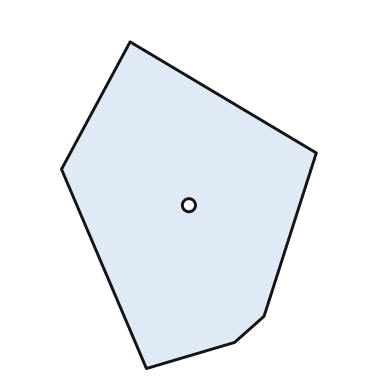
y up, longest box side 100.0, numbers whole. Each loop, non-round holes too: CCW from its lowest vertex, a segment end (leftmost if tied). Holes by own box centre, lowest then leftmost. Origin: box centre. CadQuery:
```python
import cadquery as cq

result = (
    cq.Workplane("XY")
    .moveTo(-13.0, -50.0)
    .lineTo(14.0, -42.0)
    .lineTo(23.0, -34.0)
    .lineTo(39.0, 16.0)
    .lineTo(-18.0, 50.0)
    .lineTo(-39.0, 11.0)
    .close()
    .moveTo(0.0, 0.0)
    .circle(2.0)
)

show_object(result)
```